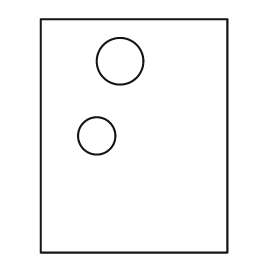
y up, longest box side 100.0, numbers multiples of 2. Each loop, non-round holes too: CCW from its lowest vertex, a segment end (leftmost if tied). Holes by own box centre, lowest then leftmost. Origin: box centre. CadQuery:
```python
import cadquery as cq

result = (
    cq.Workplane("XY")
    .moveTo(-40.0, -50.0)
    .lineTo(40.0, -50.0)
    .lineTo(40.0, 50.0)
    .lineTo(-40.0, 50.0)
    .close()
    .moveTo(-16.0, 0.0)
    .circle(8.0)
    .moveTo(-6.0, 32.0)
    .circle(10.0)
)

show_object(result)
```